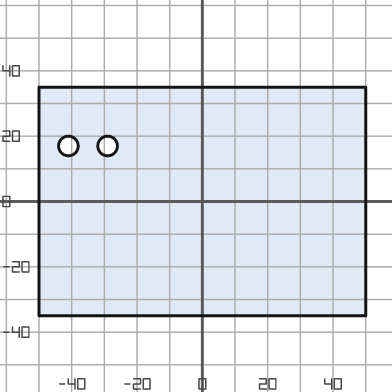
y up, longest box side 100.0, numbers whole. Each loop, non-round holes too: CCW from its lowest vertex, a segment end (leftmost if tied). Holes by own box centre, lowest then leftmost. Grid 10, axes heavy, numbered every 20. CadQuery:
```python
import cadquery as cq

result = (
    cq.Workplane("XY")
    .moveTo(-50.0, -35.0)
    .lineTo(50.0, -35.0)
    .lineTo(50.0, 35.0)
    .lineTo(-50.0, 35.0)
    .close()
    .moveTo(-41.0, 17.0)
    .circle(3.0)
    .moveTo(-29.0, 17.0)
    .circle(3.0)
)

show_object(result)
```